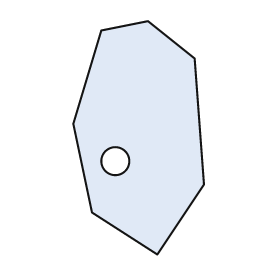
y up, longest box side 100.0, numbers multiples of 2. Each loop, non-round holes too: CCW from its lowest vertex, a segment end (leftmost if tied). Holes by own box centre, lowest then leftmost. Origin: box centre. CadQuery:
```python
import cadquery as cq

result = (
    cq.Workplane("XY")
    .moveTo(8.0, -50.0)
    .lineTo(28.0, -20.0)
    .lineTo(24.0, 34.0)
    .lineTo(4.0, 50.0)
    .lineTo(-16.0, 46.0)
    .lineTo(-28.0, 6.0)
    .lineTo(-20.0, -32.0)
    .close()
    .moveTo(-10.0, -10.0)
    .circle(6.0)
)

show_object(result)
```